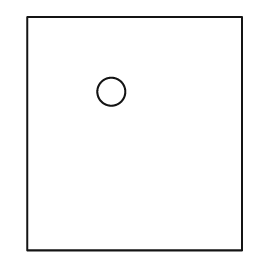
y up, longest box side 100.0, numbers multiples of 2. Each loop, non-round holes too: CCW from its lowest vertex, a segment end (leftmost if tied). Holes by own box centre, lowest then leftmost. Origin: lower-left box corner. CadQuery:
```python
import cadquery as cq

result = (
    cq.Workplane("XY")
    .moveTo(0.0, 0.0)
    .lineTo(92.0, 0.0)
    .lineTo(92.0, 100.0)
    .lineTo(0.0, 100.0)
    .close()
    .moveTo(36.0, 68.0)
    .circle(6.0)
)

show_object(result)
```